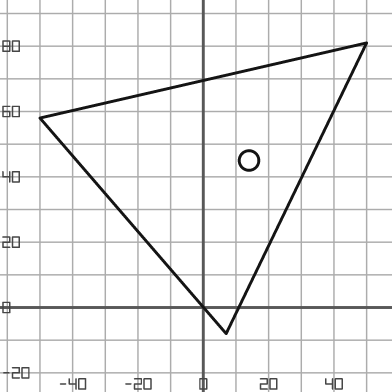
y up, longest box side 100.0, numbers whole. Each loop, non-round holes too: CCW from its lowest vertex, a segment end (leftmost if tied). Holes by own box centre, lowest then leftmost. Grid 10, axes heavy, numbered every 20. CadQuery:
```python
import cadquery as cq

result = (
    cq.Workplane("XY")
    .moveTo(7.0, -8.0)
    .lineTo(50.0, 81.0)
    .lineTo(-50.0, 58.0)
    .close()
    .moveTo(14.0, 45.0)
    .circle(3.0)
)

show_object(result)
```